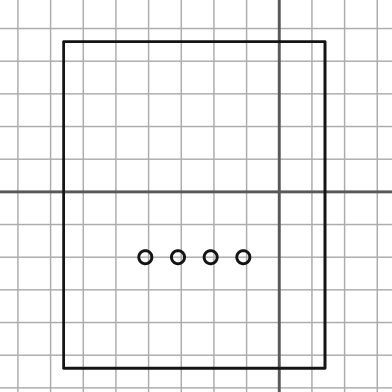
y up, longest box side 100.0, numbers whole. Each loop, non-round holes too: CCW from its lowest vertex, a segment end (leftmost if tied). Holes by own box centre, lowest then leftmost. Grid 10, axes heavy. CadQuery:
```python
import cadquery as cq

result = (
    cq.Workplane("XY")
    .moveTo(-66.0, -54.0)
    .lineTo(14.0, -54.0)
    .lineTo(14.0, 46.0)
    .lineTo(-66.0, 46.0)
    .close()
    .moveTo(-41.0, -20.0)
    .circle(2.0)
    .moveTo(-31.0, -20.0)
    .circle(2.0)
    .moveTo(-21.0, -20.0)
    .circle(2.0)
    .moveTo(-11.0, -20.0)
    .circle(2.0)
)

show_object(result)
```